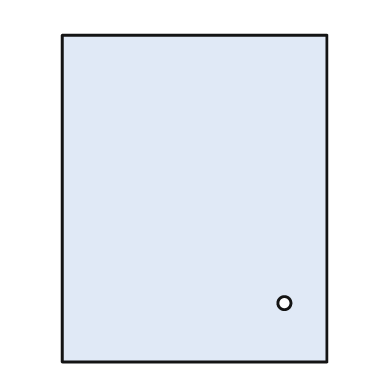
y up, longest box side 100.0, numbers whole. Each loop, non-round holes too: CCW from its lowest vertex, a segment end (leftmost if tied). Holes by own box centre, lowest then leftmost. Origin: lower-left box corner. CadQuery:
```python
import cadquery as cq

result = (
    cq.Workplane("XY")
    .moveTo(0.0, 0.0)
    .lineTo(81.0, 0.0)
    .lineTo(81.0, 100.0)
    .lineTo(0.0, 100.0)
    .close()
    .moveTo(68.0, 18.0)
    .circle(2.0)
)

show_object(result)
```